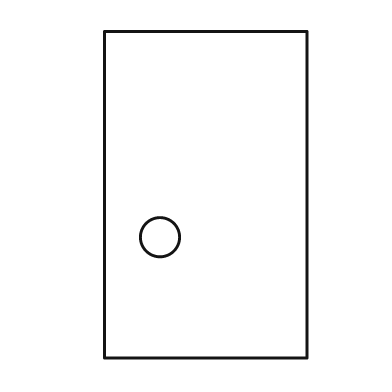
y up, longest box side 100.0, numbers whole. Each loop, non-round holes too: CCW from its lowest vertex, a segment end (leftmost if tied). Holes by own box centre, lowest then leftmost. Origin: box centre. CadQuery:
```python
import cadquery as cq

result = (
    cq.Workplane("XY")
    .moveTo(-31.0, -50.0)
    .lineTo(31.0, -50.0)
    .lineTo(31.0, 50.0)
    .lineTo(-31.0, 50.0)
    .close()
    .moveTo(-14.0, -13.0)
    .circle(6.0)
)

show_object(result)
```